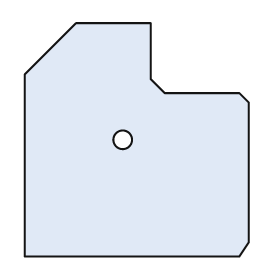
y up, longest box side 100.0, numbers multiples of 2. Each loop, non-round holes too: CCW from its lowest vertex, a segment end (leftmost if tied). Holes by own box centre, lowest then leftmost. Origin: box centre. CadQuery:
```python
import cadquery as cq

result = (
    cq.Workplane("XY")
    .moveTo(-48.0, -50.0)
    .lineTo(44.0, -50.0)
    .lineTo(48.0, -44.0)
    .lineTo(48.0, 16.0)
    .lineTo(44.0, 20.0)
    .lineTo(12.0, 20.0)
    .lineTo(6.0, 26.0)
    .lineTo(6.0, 50.0)
    .lineTo(-26.0, 50.0)
    .lineTo(-48.0, 28.0)
    .close()
    .moveTo(-6.0, 0.0)
    .circle(4.0)
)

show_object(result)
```